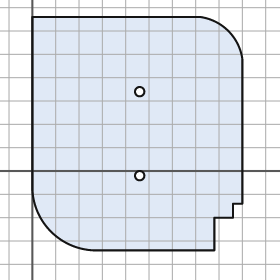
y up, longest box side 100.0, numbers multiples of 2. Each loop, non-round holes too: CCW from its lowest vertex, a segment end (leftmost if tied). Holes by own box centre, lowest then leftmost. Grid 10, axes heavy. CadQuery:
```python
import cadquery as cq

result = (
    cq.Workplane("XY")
    .moveTo(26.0, -34.0)
    .lineTo(78.0, -34.0)
    .lineTo(78.0, -20.0)
    .lineTo(86.0, -20.0)
    .lineTo(86.0, -14.0)
    .lineTo(90.0, -14.0)
    .lineTo(90.0, 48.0)
    .threePointArc((84.0, 60.0), (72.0, 66.0))
    .lineTo(0.0, 66.0)
    .lineTo(0.0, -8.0)
    .threePointArc((8.0, -26.0), (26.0, -34.0))
    .close()
    .moveTo(46.0, -2.0)
    .circle(2.0)
    .moveTo(46.0, 34.0)
    .circle(2.0)
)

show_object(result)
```